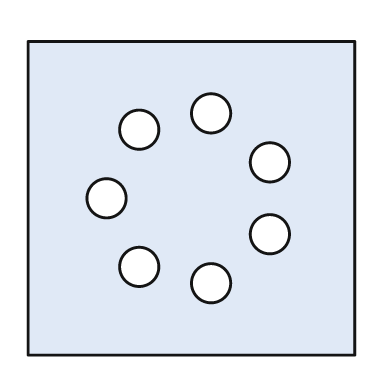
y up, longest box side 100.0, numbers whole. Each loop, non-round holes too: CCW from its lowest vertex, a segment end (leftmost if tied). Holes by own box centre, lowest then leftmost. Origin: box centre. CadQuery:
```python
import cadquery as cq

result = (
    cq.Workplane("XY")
    .moveTo(-50.0, -48.0)
    .lineTo(50.0, -48.0)
    .lineTo(50.0, 48.0)
    .lineTo(-50.0, 48.0)
    .close()
    .moveTo(6.0, -26.0)
    .circle(6.0)
    .moveTo(-16.0, -21.0)
    .circle(6.0)
    .moveTo(24.0, -11.0)
    .circle(6.0)
    .moveTo(-26.0, 0.0)
    .circle(6.0)
    .moveTo(24.0, 11.0)
    .circle(6.0)
    .moveTo(-16.0, 21.0)
    .circle(6.0)
    .moveTo(6.0, 26.0)
    .circle(6.0)
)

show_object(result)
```